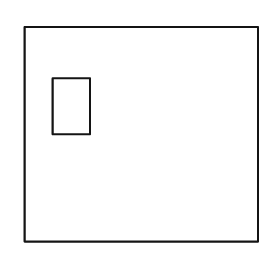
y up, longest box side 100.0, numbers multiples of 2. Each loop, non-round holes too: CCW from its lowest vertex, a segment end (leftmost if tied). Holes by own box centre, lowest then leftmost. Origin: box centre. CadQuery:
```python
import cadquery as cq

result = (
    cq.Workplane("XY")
    .moveTo(-50.0, -46.0)
    .lineTo(50.0, -46.0)
    .lineTo(50.0, 46.0)
    .lineTo(-50.0, 46.0)
    .close()
    .moveTo(-38.0, 0.0)
    .lineTo(-22.0, 0.0)
    .lineTo(-22.0, 24.0)
    .lineTo(-38.0, 24.0)
    .close()
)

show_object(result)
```